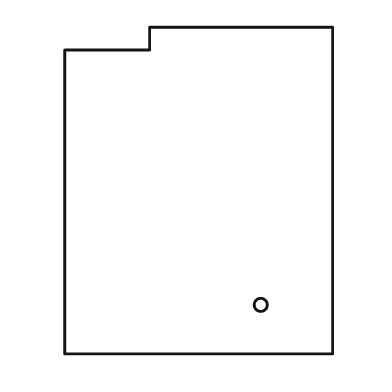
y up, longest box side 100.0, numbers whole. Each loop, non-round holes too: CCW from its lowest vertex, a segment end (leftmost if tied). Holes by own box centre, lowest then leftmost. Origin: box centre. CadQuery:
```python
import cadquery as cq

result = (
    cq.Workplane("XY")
    .moveTo(-41.0, -50.0)
    .lineTo(41.0, -50.0)
    .lineTo(41.0, 50.0)
    .lineTo(-15.0, 50.0)
    .lineTo(-15.0, 43.0)
    .lineTo(-41.0, 43.0)
    .close()
    .moveTo(19.0, -35.0)
    .circle(2.0)
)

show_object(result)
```